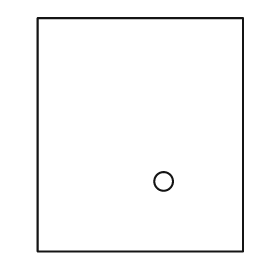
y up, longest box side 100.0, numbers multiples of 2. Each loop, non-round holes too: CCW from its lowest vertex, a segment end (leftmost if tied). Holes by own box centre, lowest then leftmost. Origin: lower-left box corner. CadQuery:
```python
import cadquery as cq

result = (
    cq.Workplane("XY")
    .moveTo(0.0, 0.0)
    .lineTo(88.0, 0.0)
    .lineTo(88.0, 100.0)
    .lineTo(0.0, 100.0)
    .close()
    .moveTo(54.0, 30.0)
    .circle(4.0)
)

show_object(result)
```